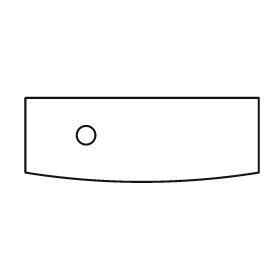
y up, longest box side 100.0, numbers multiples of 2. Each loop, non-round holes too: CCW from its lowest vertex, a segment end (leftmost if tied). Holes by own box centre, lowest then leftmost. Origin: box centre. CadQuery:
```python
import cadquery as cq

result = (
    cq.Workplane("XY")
    .moveTo(-50.0, -14.0)
    .threePointArc((0.0, -18.0), (50.0, -14.0))
    .lineTo(50.0, 18.0)
    .lineTo(-50.0, 18.0)
    .close()
    .moveTo(-24.0, 2.0)
    .circle(4.0)
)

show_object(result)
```